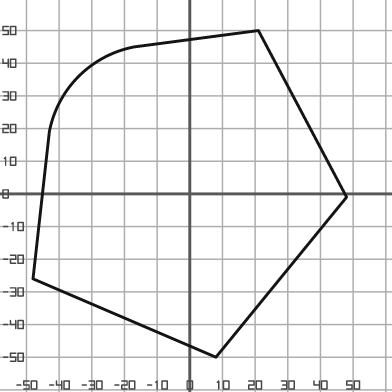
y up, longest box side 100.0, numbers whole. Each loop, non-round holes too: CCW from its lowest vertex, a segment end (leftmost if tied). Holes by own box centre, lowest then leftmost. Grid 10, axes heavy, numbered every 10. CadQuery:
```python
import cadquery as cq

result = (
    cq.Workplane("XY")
    .moveTo(8.0, -50.0)
    .lineTo(48.0, -1.0)
    .lineTo(21.0, 50.0)
    .lineTo(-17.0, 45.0)
    .threePointArc((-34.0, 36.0), (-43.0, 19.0))
    .lineTo(-48.0, -26.0)
    .close()
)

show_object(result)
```